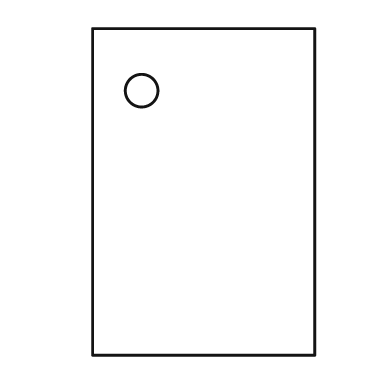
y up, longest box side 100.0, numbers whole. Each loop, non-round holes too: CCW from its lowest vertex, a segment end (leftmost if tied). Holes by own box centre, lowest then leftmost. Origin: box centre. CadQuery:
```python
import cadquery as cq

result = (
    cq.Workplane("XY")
    .moveTo(-34.0, -50.0)
    .lineTo(34.0, -50.0)
    .lineTo(34.0, 50.0)
    .lineTo(-34.0, 50.0)
    .close()
    .moveTo(-19.0, 31.0)
    .circle(5.0)
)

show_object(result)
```